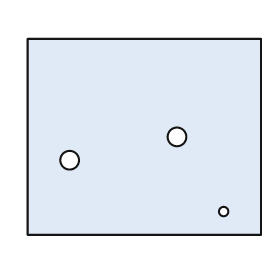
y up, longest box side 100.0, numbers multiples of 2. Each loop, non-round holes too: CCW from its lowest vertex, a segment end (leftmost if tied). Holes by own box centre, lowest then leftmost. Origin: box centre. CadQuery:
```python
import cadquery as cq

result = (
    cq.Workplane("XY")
    .moveTo(-50.0, -42.0)
    .lineTo(50.0, -42.0)
    .lineTo(50.0, 42.0)
    .lineTo(-50.0, 42.0)
    .close()
    .moveTo(34.0, -32.0)
    .circle(2.0)
    .moveTo(-32.0, -10.0)
    .circle(4.0)
    .moveTo(14.0, 0.0)
    .circle(4.0)
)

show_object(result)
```